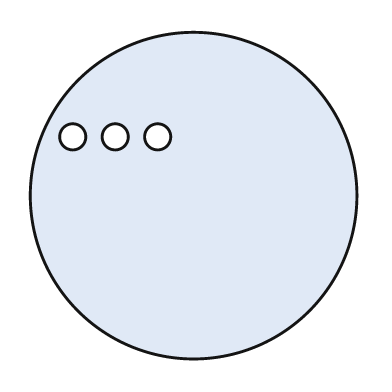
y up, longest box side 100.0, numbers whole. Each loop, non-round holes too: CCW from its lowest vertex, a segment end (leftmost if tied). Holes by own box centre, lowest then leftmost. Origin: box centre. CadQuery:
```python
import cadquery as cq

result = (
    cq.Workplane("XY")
    .moveTo(0.0, 0.0)
    .circle(50.0)
    .moveTo(-37.0, 18.0)
    .circle(4.0)
    .moveTo(-24.0, 18.0)
    .circle(4.0)
    .moveTo(-11.0, 18.0)
    .circle(4.0)
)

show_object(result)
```